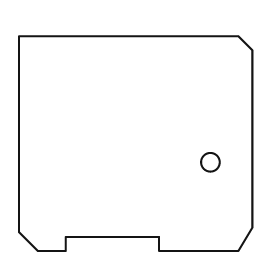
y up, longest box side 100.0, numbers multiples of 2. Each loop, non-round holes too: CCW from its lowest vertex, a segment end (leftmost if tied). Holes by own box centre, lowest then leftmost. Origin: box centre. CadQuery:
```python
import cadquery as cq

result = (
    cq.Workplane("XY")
    .moveTo(-42.0, -46.0)
    .lineTo(-30.0, -46.0)
    .lineTo(-30.0, -40.0)
    .lineTo(10.0, -40.0)
    .lineTo(10.0, -46.0)
    .lineTo(44.0, -46.0)
    .lineTo(50.0, -36.0)
    .lineTo(50.0, 40.0)
    .lineTo(44.0, 46.0)
    .lineTo(-50.0, 46.0)
    .lineTo(-50.0, -38.0)
    .close()
    .moveTo(32.0, -8.0)
    .circle(4.0)
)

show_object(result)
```